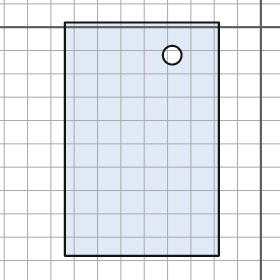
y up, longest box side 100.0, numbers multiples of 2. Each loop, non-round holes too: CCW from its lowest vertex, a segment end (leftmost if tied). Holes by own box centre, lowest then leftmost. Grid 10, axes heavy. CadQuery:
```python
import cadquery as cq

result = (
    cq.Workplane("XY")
    .moveTo(-84.0, -98.0)
    .lineTo(-18.0, -98.0)
    .lineTo(-18.0, 2.0)
    .lineTo(-84.0, 2.0)
    .close()
    .moveTo(-38.0, -12.0)
    .circle(4.0)
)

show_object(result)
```